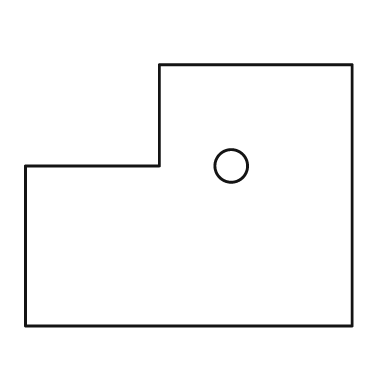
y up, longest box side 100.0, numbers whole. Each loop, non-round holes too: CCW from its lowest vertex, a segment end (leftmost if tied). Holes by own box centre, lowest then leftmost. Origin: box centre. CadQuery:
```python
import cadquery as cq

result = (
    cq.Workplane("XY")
    .moveTo(-50.0, -40.0)
    .lineTo(50.0, -40.0)
    .lineTo(50.0, 40.0)
    .lineTo(-9.0, 40.0)
    .lineTo(-9.0, 9.0)
    .lineTo(-50.0, 9.0)
    .close()
    .moveTo(13.0, 9.0)
    .circle(5.0)
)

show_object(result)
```